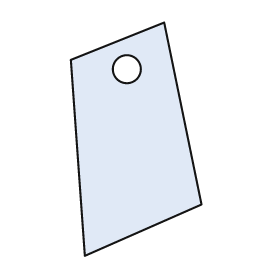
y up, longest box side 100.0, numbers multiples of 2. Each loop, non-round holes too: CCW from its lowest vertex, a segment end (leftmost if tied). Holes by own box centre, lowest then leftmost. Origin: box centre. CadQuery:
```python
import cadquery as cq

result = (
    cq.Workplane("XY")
    .moveTo(-22.0, -50.0)
    .lineTo(28.0, -28.0)
    .lineTo(12.0, 50.0)
    .lineTo(-28.0, 34.0)
    .close()
    .moveTo(-4.0, 30.0)
    .circle(6.0)
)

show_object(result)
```